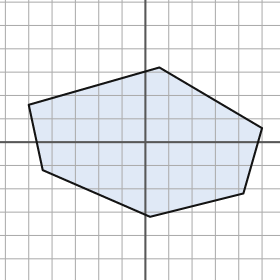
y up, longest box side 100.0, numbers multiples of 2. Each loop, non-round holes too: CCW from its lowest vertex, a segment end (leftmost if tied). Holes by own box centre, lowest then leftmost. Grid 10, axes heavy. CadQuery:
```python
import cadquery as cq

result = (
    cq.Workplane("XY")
    .moveTo(2.0, -32.0)
    .lineTo(42.0, -22.0)
    .lineTo(50.0, 6.0)
    .lineTo(6.0, 32.0)
    .lineTo(-50.0, 16.0)
    .lineTo(-44.0, -12.0)
    .close()
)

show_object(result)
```